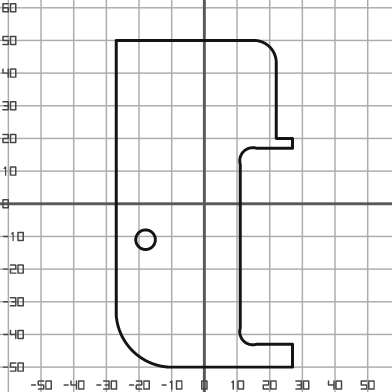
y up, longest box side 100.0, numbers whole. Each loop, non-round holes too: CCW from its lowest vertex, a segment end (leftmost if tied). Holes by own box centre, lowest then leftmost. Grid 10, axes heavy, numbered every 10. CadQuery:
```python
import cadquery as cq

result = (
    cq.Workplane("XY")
    .moveTo(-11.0, -50.0)
    .lineTo(27.0, -50.0)
    .lineTo(27.0, -43.0)
    .lineTo(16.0, -43.0)
    .threePointArc((12.0, -42.0), (11.0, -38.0))
    .lineTo(11.0, 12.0)
    .threePointArc((12.0, 16.0), (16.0, 17.0))
    .lineTo(27.0, 17.0)
    .lineTo(27.0, 20.0)
    .lineTo(22.0, 20.0)
    .lineTo(22.0, 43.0)
    .threePointArc((20.0, 48.0), (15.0, 50.0))
    .lineTo(-27.0, 50.0)
    .lineTo(-27.0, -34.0)
    .threePointArc((-22.0, -45.0), (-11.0, -50.0))
    .close()
    .moveTo(-18.0, -11.0)
    .circle(3.0)
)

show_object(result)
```